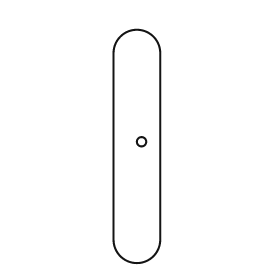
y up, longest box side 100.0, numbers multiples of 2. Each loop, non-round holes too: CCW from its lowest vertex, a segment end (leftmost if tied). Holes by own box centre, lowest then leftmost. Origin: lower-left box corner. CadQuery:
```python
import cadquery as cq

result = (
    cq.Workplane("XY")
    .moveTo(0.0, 10.0)
    .threePointArc((10.0, 0.0), (20.0, 10.0))
    .lineTo(20.0, 90.0)
    .threePointArc((10.0, 100.0), (0.0, 90.0))
    .close()
    .moveTo(12.0, 52.0)
    .circle(2.0)
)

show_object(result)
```